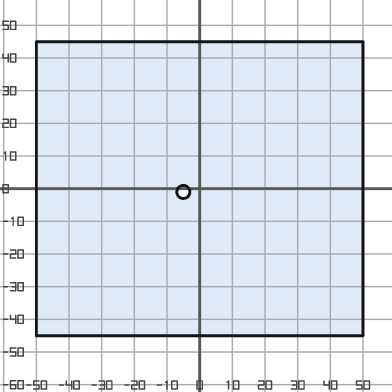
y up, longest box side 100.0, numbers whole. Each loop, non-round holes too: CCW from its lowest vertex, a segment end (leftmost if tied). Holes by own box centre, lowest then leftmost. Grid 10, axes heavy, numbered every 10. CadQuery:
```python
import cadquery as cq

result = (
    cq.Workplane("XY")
    .moveTo(-50.0, -45.0)
    .lineTo(50.0, -45.0)
    .lineTo(50.0, 45.0)
    .lineTo(-50.0, 45.0)
    .close()
    .moveTo(-5.0, -1.0)
    .circle(2.0)
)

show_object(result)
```